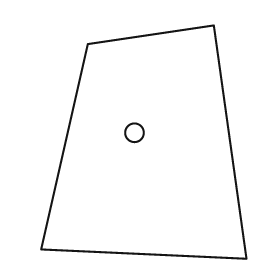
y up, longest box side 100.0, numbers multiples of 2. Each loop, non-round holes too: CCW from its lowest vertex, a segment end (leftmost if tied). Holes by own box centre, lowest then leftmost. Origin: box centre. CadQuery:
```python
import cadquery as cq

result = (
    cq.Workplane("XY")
    .moveTo(44.0, -50.0)
    .lineTo(30.0, 50.0)
    .lineTo(-24.0, 42.0)
    .lineTo(-44.0, -46.0)
    .close()
    .moveTo(-4.0, 4.0)
    .circle(4.0)
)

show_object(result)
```